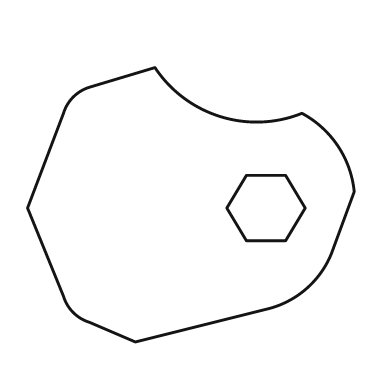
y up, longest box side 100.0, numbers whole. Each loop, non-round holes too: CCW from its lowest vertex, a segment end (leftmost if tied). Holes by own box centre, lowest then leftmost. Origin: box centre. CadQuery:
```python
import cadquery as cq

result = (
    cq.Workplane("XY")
    .moveTo(-17.0, -42.0)
    .lineTo(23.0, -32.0)
    .threePointArc((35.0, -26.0), (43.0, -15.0))
    .lineTo(50.0, 4.0)
    .threePointArc((45.0, 18.0), (34.0, 28.0))
    .threePointArc((9.0, 27.0), (-11.0, 42.0))
    .lineTo(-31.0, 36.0)
    .threePointArc((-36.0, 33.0), (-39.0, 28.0))
    .lineTo(-50.0, -1.0)
    .lineTo(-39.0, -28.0)
    .threePointArc((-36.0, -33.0), (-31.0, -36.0))
    .close()
    .moveTo(17.0, -11.0)
    .lineTo(29.0, -11.0)
    .lineTo(35.0, -1.0)
    .lineTo(29.0, 9.0)
    .lineTo(17.0, 9.0)
    .lineTo(11.0, -1.0)
    .close()
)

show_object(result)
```